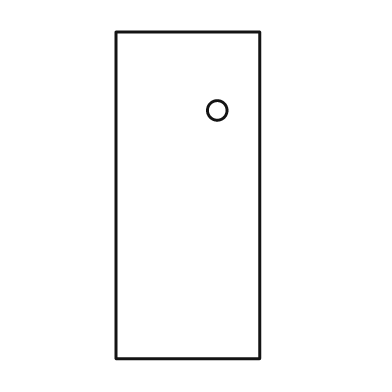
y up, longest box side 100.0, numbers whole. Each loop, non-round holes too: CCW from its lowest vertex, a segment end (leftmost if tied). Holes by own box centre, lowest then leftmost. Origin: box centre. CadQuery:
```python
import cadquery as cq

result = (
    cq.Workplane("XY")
    .moveTo(-22.0, -50.0)
    .lineTo(22.0, -50.0)
    .lineTo(22.0, 50.0)
    .lineTo(-22.0, 50.0)
    .close()
    .moveTo(9.0, 26.0)
    .circle(3.0)
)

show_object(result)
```